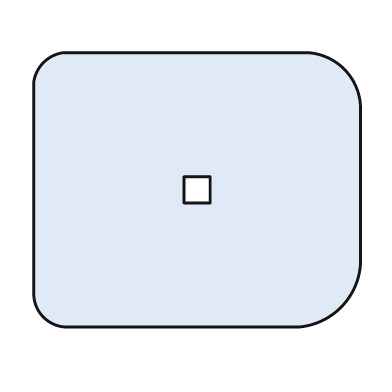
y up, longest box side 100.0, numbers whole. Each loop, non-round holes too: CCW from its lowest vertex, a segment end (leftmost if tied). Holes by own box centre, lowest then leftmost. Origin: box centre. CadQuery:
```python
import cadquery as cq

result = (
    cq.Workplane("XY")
    .moveTo(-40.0, -42.0)
    .lineTo(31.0, -42.0)
    .threePointArc((44.0, -36.0), (50.0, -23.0))
    .lineTo(50.0, 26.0)
    .threePointArc((45.0, 37.0), (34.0, 42.0))
    .lineTo(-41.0, 42.0)
    .threePointArc((-47.0, 39.0), (-50.0, 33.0))
    .lineTo(-50.0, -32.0)
    .threePointArc((-47.0, -39.0), (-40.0, -42.0))
    .close()
    .moveTo(-4.0, -4.0)
    .lineTo(4.0, -4.0)
    .lineTo(4.0, 4.0)
    .lineTo(-4.0, 4.0)
    .close()
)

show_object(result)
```